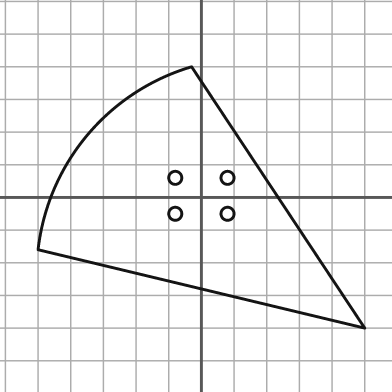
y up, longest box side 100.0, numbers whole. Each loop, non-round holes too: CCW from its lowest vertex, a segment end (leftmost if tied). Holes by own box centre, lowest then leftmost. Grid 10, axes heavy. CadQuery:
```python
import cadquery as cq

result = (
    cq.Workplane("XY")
    .moveTo(50.0, -40.0)
    .lineTo(-3.0, 40.0)
    .threePointArc((-35.0, 19.0), (-50.0, -16.0))
    .close()
    .moveTo(-8.0, -5.0)
    .circle(2.0)
    .moveTo(8.0, -5.0)
    .circle(2.0)
    .moveTo(-8.0, 6.0)
    .circle(2.0)
    .moveTo(8.0, 6.0)
    .circle(2.0)
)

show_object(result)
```